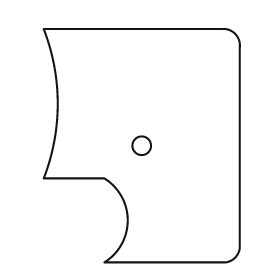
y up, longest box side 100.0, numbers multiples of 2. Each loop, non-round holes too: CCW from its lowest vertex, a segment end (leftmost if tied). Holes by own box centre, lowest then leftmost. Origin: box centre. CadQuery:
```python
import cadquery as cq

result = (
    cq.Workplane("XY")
    .moveTo(-16.0, -50.0)
    .lineTo(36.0, -50.0)
    .threePointArc((40.0, -48.0), (42.0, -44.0))
    .lineTo(42.0, 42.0)
    .threePointArc((40.0, 48.0), (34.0, 50.0))
    .lineTo(-42.0, 50.0)
    .threePointArc((-36.0, 18.0), (-42.0, -14.0))
    .lineTo(-16.0, -14.0)
    .threePointArc((-6.0, -32.0), (-16.0, -50.0))
    .close()
    .moveTo(0.0, 0.0)
    .circle(4.0)
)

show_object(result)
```